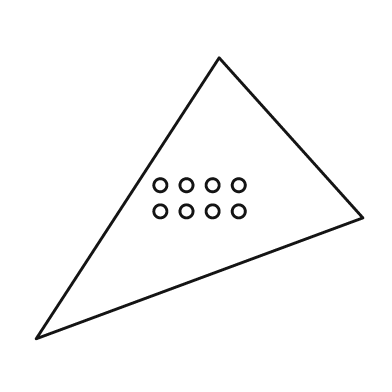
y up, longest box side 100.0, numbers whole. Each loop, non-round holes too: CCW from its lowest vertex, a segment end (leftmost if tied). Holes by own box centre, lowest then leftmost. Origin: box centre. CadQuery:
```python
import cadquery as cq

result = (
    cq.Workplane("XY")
    .moveTo(-50.0, -43.0)
    .lineTo(50.0, -6.0)
    .lineTo(6.0, 43.0)
    .close()
    .moveTo(-12.0, -4.0)
    .circle(2.0)
    .moveTo(-4.0, -4.0)
    .circle(2.0)
    .moveTo(4.0, -4.0)
    .circle(2.0)
    .moveTo(12.0, -4.0)
    .circle(2.0)
    .moveTo(-12.0, 4.0)
    .circle(2.0)
    .moveTo(-4.0, 4.0)
    .circle(2.0)
    .moveTo(4.0, 4.0)
    .circle(2.0)
    .moveTo(12.0, 4.0)
    .circle(2.0)
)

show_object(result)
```